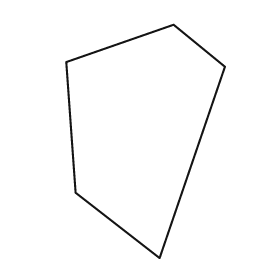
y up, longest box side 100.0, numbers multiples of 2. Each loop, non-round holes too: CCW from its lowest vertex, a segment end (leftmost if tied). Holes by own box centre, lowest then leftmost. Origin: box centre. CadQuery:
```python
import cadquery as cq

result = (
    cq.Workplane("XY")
    .moveTo(6.0, -50.0)
    .lineTo(34.0, 32.0)
    .lineTo(12.0, 50.0)
    .lineTo(-34.0, 34.0)
    .lineTo(-30.0, -22.0)
    .close()
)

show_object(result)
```